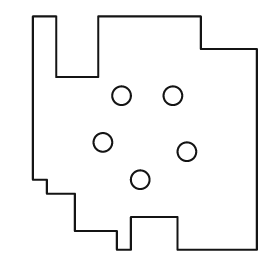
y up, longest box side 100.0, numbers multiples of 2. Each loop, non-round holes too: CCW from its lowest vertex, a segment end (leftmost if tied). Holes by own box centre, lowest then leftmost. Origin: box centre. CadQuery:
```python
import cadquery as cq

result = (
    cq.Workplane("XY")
    .moveTo(-12.0, -50.0)
    .lineTo(-6.0, -50.0)
    .lineTo(-6.0, -36.0)
    .lineTo(14.0, -36.0)
    .lineTo(14.0, -50.0)
    .lineTo(48.0, -50.0)
    .lineTo(48.0, 36.0)
    .lineTo(24.0, 36.0)
    .lineTo(24.0, 50.0)
    .lineTo(-20.0, 50.0)
    .lineTo(-20.0, 24.0)
    .lineTo(-38.0, 24.0)
    .lineTo(-38.0, 50.0)
    .lineTo(-48.0, 50.0)
    .lineTo(-48.0, -20.0)
    .lineTo(-42.0, -20.0)
    .lineTo(-42.0, -26.0)
    .lineTo(-30.0, -26.0)
    .lineTo(-30.0, -42.0)
    .lineTo(-12.0, -42.0)
    .close()
    .moveTo(-2.0, -20.0)
    .circle(4.0)
    .moveTo(18.0, -8.0)
    .circle(4.0)
    .moveTo(-18.0, -4.0)
    .circle(4.0)
    .moveTo(-10.0, 16.0)
    .circle(4.0)
    .moveTo(12.0, 16.0)
    .circle(4.0)
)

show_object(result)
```